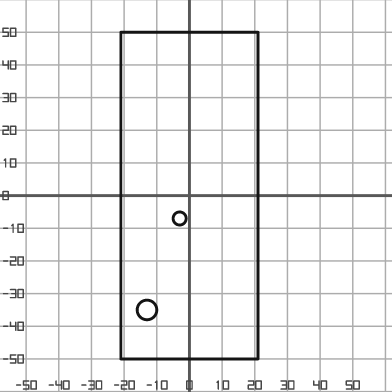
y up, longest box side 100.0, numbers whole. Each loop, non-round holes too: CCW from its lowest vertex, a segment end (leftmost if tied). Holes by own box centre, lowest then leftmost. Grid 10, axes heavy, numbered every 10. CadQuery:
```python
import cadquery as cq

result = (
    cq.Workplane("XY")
    .moveTo(-21.0, -50.0)
    .lineTo(21.0, -50.0)
    .lineTo(21.0, 50.0)
    .lineTo(-21.0, 50.0)
    .close()
    .moveTo(-13.0, -35.0)
    .circle(3.0)
    .moveTo(-3.0, -7.0)
    .circle(2.0)
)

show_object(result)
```